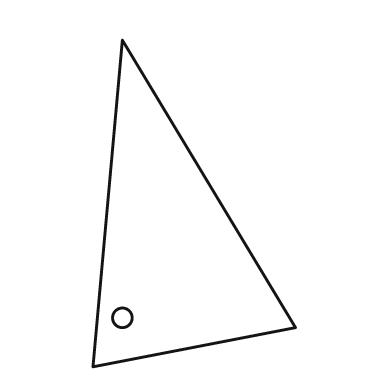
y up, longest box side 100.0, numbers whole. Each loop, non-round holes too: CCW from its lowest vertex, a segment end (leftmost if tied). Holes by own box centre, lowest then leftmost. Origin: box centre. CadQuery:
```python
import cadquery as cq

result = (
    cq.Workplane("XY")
    .moveTo(-31.0, -50.0)
    .lineTo(31.0, -38.0)
    .lineTo(-22.0, 50.0)
    .close()
    .moveTo(-22.0, -35.0)
    .circle(3.0)
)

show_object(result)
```